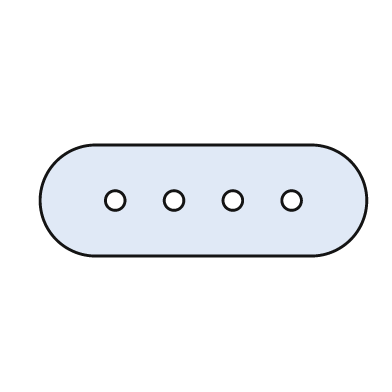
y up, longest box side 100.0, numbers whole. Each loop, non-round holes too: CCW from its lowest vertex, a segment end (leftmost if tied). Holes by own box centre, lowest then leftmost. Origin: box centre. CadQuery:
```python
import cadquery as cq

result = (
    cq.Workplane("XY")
    .moveTo(-33.0, -17.0)
    .lineTo(33.0, -17.0)
    .threePointArc((50.0, 0.0), (33.0, 17.0))
    .lineTo(-33.0, 17.0)
    .threePointArc((-50.0, 0.0), (-33.0, -17.0))
    .close()
    .moveTo(-27.0, 0.0)
    .circle(3.0)
    .moveTo(-9.0, 0.0)
    .circle(3.0)
    .moveTo(9.0, 0.0)
    .circle(3.0)
    .moveTo(27.0, 0.0)
    .circle(3.0)
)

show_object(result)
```